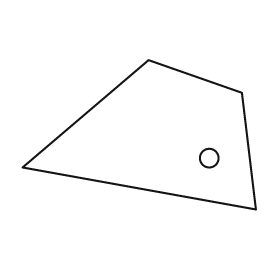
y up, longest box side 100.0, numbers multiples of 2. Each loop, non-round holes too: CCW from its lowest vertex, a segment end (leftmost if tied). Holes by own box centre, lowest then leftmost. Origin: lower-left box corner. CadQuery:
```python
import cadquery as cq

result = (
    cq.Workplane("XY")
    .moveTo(100.0, 0.0)
    .lineTo(94.0, 50.0)
    .lineTo(54.0, 64.0)
    .lineTo(0.0, 18.0)
    .close()
    .moveTo(80.0, 22.0)
    .circle(4.0)
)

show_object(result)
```